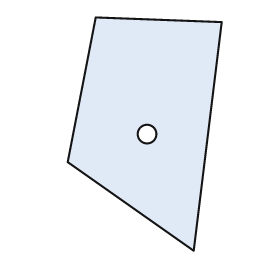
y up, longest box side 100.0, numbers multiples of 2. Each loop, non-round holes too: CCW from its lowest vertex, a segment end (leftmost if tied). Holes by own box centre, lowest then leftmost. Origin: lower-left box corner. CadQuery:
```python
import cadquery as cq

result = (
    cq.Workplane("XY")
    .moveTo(54.0, 0.0)
    .lineTo(66.0, 98.0)
    .lineTo(12.0, 100.0)
    .lineTo(0.0, 38.0)
    .close()
    .moveTo(34.0, 50.0)
    .circle(4.0)
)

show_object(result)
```